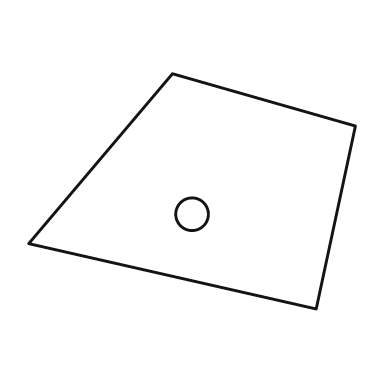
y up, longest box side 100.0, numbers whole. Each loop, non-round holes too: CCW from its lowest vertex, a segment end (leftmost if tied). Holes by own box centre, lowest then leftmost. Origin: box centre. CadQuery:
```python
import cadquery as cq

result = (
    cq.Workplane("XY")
    .moveTo(38.0, -36.0)
    .lineTo(50.0, 20.0)
    .lineTo(-6.0, 36.0)
    .lineTo(-50.0, -16.0)
    .close()
    .moveTo(0.0, -7.0)
    .circle(5.0)
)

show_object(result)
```